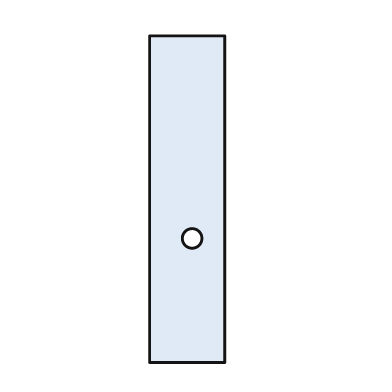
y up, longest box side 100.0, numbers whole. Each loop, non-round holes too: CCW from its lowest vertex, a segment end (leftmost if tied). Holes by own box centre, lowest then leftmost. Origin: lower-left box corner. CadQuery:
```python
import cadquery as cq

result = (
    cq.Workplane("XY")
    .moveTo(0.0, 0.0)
    .lineTo(23.0, 0.0)
    .lineTo(23.0, 100.0)
    .lineTo(0.0, 100.0)
    .close()
    .moveTo(13.0, 38.0)
    .circle(3.0)
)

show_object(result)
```